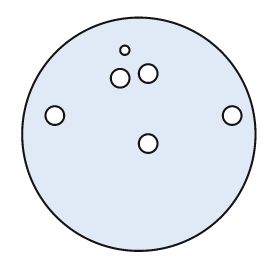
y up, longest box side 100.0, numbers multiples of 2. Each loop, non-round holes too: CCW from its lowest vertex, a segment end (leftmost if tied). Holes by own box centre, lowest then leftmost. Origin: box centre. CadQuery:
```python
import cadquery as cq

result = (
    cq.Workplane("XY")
    .moveTo(0.0, 0.0)
    .circle(50.0)
    .moveTo(4.0, -4.0)
    .circle(4.0)
    .moveTo(-36.0, 8.0)
    .circle(4.0)
    .moveTo(40.0, 8.0)
    .circle(4.0)
    .moveTo(-8.0, 24.0)
    .circle(4.0)
    .moveTo(4.0, 26.0)
    .circle(4.0)
    .moveTo(-6.0, 36.0)
    .circle(2.0)
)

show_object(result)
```